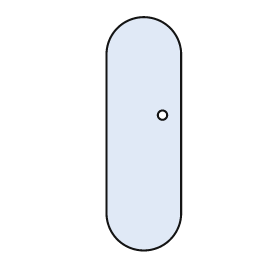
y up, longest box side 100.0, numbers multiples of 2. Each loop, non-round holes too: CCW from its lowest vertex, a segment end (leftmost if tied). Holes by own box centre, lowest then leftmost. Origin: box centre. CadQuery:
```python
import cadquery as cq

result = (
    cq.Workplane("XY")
    .moveTo(-16.0, -34.0)
    .threePointArc((0.0, -50.0), (16.0, -34.0))
    .lineTo(16.0, 34.0)
    .threePointArc((0.0, 50.0), (-16.0, 34.0))
    .close()
    .moveTo(8.0, 8.0)
    .circle(2.0)
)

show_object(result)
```